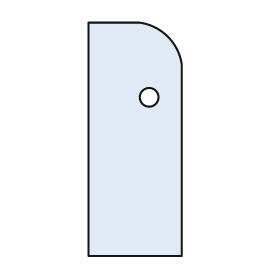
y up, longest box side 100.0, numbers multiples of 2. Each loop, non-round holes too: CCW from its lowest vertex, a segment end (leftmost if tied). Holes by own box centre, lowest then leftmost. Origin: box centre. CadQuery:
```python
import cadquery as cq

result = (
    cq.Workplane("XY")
    .moveTo(-20.0, -50.0)
    .lineTo(20.0, -50.0)
    .lineTo(20.0, 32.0)
    .threePointArc((14.0, 44.0), (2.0, 50.0))
    .lineTo(-20.0, 50.0)
    .close()
    .moveTo(6.0, 18.0)
    .circle(4.0)
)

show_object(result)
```